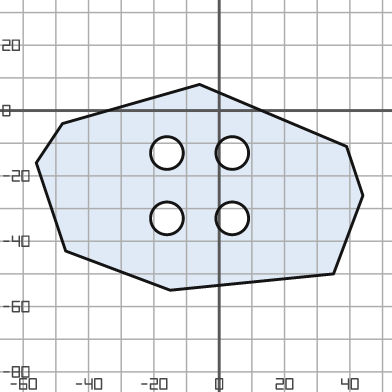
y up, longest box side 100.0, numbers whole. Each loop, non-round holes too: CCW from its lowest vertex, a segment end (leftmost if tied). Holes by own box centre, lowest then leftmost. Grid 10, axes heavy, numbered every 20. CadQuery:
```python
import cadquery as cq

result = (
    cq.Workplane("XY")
    .moveTo(-15.0, -55.0)
    .lineTo(35.0, -50.0)
    .lineTo(44.0, -26.0)
    .lineTo(39.0, -11.0)
    .lineTo(-6.0, 8.0)
    .lineTo(-48.0, -4.0)
    .lineTo(-56.0, -16.0)
    .lineTo(-47.0, -43.0)
    .close()
    .moveTo(-16.0, -33.0)
    .circle(5.0)
    .moveTo(4.0, -33.0)
    .circle(5.0)
    .moveTo(-16.0, -13.0)
    .circle(5.0)
    .moveTo(4.0, -13.0)
    .circle(5.0)
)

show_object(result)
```